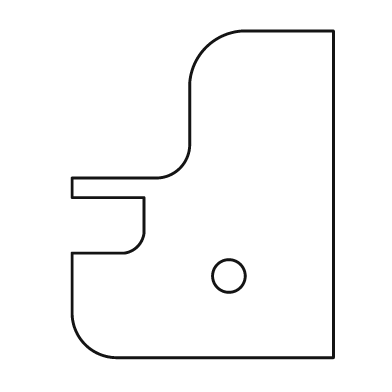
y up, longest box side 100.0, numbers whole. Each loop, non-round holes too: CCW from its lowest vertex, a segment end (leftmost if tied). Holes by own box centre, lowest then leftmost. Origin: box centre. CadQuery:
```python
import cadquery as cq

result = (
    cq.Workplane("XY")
    .moveTo(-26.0, -50.0)
    .lineTo(40.0, -50.0)
    .lineTo(40.0, 50.0)
    .lineTo(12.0, 50.0)
    .threePointArc((1.0, 45.0), (-4.0, 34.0))
    .lineTo(-4.0, 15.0)
    .threePointArc((-7.0, 8.0), (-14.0, 5.0))
    .lineTo(-40.0, 5.0)
    .lineTo(-40.0, -1.0)
    .lineTo(-18.0, -1.0)
    .lineTo(-18.0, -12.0)
    .threePointArc((-20.0, -16.0), (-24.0, -18.0))
    .lineTo(-40.0, -18.0)
    .lineTo(-40.0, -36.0)
    .threePointArc((-36.0, -46.0), (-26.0, -50.0))
    .close()
    .moveTo(8.0, -25.0)
    .circle(5.0)
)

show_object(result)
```